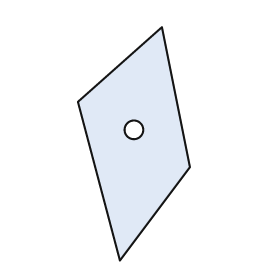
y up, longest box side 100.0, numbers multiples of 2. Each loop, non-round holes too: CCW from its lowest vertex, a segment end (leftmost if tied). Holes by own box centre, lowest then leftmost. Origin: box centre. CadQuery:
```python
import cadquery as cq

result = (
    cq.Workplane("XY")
    .moveTo(-6.0, -50.0)
    .lineTo(24.0, -10.0)
    .lineTo(12.0, 50.0)
    .lineTo(-24.0, 18.0)
    .close()
    .moveTo(0.0, 6.0)
    .circle(4.0)
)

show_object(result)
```